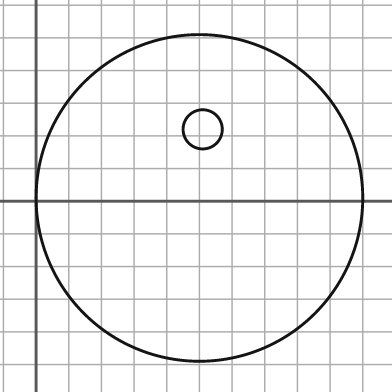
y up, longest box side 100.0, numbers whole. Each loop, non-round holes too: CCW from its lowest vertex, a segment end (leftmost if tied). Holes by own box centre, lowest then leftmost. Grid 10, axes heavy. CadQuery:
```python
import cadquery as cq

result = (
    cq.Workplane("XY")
    .moveTo(50.0, 1.0)
    .circle(50.0)
    .moveTo(51.0, 22.0)
    .circle(6.0)
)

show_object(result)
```